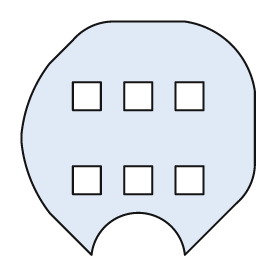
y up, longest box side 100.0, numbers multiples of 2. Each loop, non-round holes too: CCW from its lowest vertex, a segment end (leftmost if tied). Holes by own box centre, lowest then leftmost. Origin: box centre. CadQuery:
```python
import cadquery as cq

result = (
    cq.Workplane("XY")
    .moveTo(-20.0, -50.0)
    .threePointArc((0.0, -32.0), (20.0, -50.0))
    .lineTo(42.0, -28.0)
    .threePointArc((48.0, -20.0), (50.0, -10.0))
    .lineTo(50.0, 20.0)
    .threePointArc((40.0, 40.0), (20.0, 50.0))
    .lineTo(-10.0, 50.0)
    .threePointArc((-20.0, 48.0), (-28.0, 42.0))
    .lineTo(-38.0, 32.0)
    .threePointArc((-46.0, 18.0), (-50.0, 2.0))
    .lineTo(-50.0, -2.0)
    .threePointArc((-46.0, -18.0), (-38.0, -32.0))
    .close()
    .moveTo(-28.0, -24.0)
    .lineTo(-16.0, -24.0)
    .lineTo(-16.0, -12.0)
    .lineTo(-28.0, -12.0)
    .close()
    .moveTo(-6.0, -24.0)
    .lineTo(6.0, -24.0)
    .lineTo(6.0, -12.0)
    .lineTo(-6.0, -12.0)
    .close()
    .moveTo(16.0, -24.0)
    .lineTo(28.0, -24.0)
    .lineTo(28.0, -12.0)
    .lineTo(16.0, -12.0)
    .close()
    .moveTo(-28.0, 12.0)
    .lineTo(-16.0, 12.0)
    .lineTo(-16.0, 24.0)
    .lineTo(-28.0, 24.0)
    .close()
    .moveTo(-6.0, 12.0)
    .lineTo(6.0, 12.0)
    .lineTo(6.0, 24.0)
    .lineTo(-6.0, 24.0)
    .close()
    .moveTo(16.0, 12.0)
    .lineTo(28.0, 12.0)
    .lineTo(28.0, 24.0)
    .lineTo(16.0, 24.0)
    .close()
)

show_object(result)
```